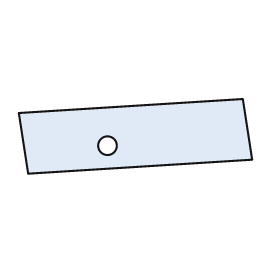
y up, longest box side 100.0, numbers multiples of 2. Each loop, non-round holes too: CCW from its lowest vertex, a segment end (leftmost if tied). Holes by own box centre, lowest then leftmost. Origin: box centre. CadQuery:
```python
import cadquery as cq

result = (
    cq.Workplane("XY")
    .moveTo(-46.0, -16.0)
    .lineTo(50.0, -10.0)
    .lineTo(46.0, 16.0)
    .lineTo(-50.0, 10.0)
    .close()
    .moveTo(-12.0, -4.0)
    .circle(4.0)
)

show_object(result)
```